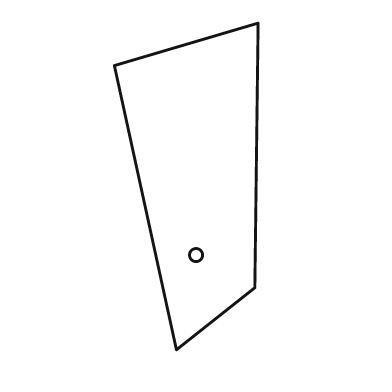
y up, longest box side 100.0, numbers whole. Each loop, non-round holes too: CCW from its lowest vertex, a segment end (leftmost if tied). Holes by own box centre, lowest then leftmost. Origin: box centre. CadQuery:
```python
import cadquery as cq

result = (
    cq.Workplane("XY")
    .moveTo(-3.0, -50.0)
    .lineTo(21.0, -31.0)
    .lineTo(22.0, 50.0)
    .lineTo(-22.0, 37.0)
    .close()
    .moveTo(3.0, -21.0)
    .circle(2.0)
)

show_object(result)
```